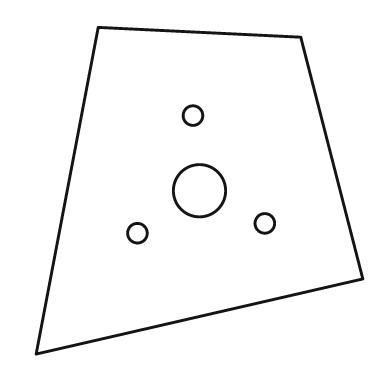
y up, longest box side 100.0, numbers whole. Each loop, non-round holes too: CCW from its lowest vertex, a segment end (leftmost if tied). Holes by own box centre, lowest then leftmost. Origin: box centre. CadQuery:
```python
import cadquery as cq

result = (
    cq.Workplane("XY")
    .moveTo(-50.0, -50.0)
    .lineTo(50.0, -27.0)
    .lineTo(31.0, 47.0)
    .lineTo(-31.0, 50.0)
    .close()
    .moveTo(-19.0, -13.0)
    .circle(3.0)
    .moveTo(20.0, -10.0)
    .circle(3.0)
    .moveTo(0.0, 0.0)
    .circle(8.0)
    .moveTo(-2.0, 23.0)
    .circle(3.0)
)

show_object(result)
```